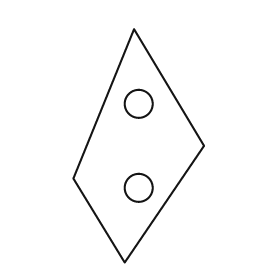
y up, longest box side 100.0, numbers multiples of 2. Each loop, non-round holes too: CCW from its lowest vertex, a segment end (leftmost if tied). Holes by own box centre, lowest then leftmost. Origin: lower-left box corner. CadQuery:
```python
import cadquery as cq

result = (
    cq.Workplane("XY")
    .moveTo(22.0, 0.0)
    .lineTo(56.0, 50.0)
    .lineTo(26.0, 100.0)
    .lineTo(0.0, 36.0)
    .close()
    .moveTo(28.0, 32.0)
    .circle(6.0)
    .moveTo(28.0, 68.0)
    .circle(6.0)
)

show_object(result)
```